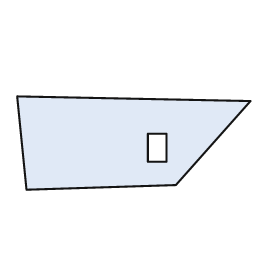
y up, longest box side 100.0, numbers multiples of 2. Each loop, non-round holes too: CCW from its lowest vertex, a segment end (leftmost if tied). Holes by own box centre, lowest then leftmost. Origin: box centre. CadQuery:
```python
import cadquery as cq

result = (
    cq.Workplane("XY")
    .moveTo(-46.0, -20.0)
    .lineTo(18.0, -18.0)
    .lineTo(50.0, 18.0)
    .lineTo(-50.0, 20.0)
    .close()
    .moveTo(6.0, -8.0)
    .lineTo(14.0, -8.0)
    .lineTo(14.0, 4.0)
    .lineTo(6.0, 4.0)
    .close()
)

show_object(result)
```